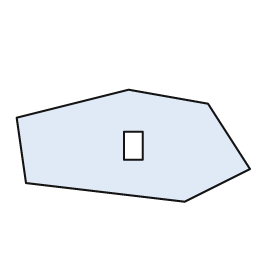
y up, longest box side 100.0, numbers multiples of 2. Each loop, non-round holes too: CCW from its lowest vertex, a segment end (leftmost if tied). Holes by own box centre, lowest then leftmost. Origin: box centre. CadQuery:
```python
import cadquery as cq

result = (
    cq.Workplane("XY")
    .moveTo(22.0, -24.0)
    .lineTo(50.0, -10.0)
    .lineTo(32.0, 18.0)
    .lineTo(-2.0, 24.0)
    .lineTo(-50.0, 12.0)
    .lineTo(-46.0, -16.0)
    .close()
    .moveTo(-4.0, -6.0)
    .lineTo(4.0, -6.0)
    .lineTo(4.0, 6.0)
    .lineTo(-4.0, 6.0)
    .close()
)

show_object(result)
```